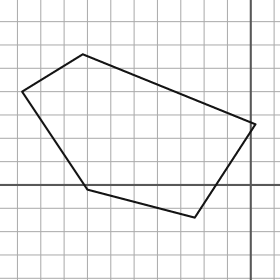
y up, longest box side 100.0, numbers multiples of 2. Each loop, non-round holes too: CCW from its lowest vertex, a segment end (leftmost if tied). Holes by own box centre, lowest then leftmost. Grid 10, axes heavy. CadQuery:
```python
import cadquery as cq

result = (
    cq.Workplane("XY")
    .moveTo(-24.0, -14.0)
    .lineTo(2.0, 26.0)
    .lineTo(-72.0, 56.0)
    .lineTo(-98.0, 40.0)
    .lineTo(-70.0, -2.0)
    .close()
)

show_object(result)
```